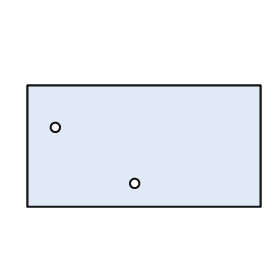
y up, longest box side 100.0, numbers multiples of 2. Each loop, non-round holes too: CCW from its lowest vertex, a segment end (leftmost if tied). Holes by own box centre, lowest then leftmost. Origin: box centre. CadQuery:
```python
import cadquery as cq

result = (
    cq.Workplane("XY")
    .moveTo(-50.0, -26.0)
    .lineTo(50.0, -26.0)
    .lineTo(50.0, 26.0)
    .lineTo(-50.0, 26.0)
    .close()
    .moveTo(-4.0, -16.0)
    .circle(2.0)
    .moveTo(-38.0, 8.0)
    .circle(2.0)
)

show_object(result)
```